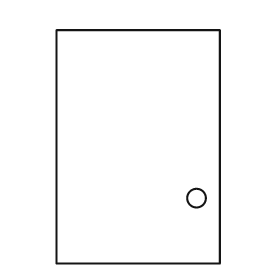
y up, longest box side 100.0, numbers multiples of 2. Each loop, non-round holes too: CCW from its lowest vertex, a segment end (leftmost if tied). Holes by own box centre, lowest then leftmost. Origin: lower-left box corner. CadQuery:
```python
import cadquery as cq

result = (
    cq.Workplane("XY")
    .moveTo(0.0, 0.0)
    .lineTo(70.0, 0.0)
    .lineTo(70.0, 100.0)
    .lineTo(0.0, 100.0)
    .close()
    .moveTo(60.0, 28.0)
    .circle(4.0)
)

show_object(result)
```